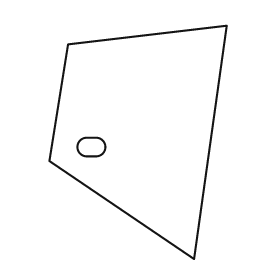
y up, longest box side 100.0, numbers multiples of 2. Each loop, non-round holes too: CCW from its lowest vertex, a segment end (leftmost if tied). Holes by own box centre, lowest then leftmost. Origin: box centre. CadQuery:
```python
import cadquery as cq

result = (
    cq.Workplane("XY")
    .moveTo(24.0, -50.0)
    .lineTo(38.0, 50.0)
    .lineTo(-30.0, 42.0)
    .lineTo(-38.0, -8.0)
    .close()
    .moveTo(-22.0, -6.0)
    .lineTo(-18.0, -6.0)
    .threePointArc((-14.0, -2.0), (-18.0, 2.0))
    .lineTo(-22.0, 2.0)
    .threePointArc((-26.0, -2.0), (-22.0, -6.0))
    .close()
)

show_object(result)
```